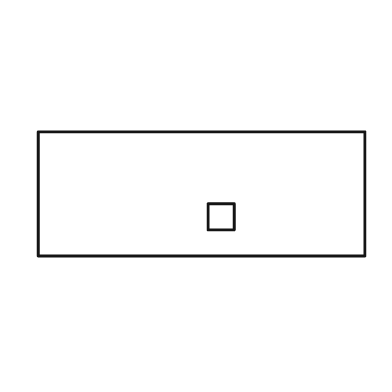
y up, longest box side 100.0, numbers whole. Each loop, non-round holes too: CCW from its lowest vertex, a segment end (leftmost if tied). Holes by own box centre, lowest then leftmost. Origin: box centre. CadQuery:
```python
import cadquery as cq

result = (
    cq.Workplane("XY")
    .moveTo(-50.0, -19.0)
    .lineTo(50.0, -19.0)
    .lineTo(50.0, 19.0)
    .lineTo(-50.0, 19.0)
    .close()
    .moveTo(2.0, -11.0)
    .lineTo(10.0, -11.0)
    .lineTo(10.0, -3.0)
    .lineTo(2.0, -3.0)
    .close()
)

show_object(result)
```